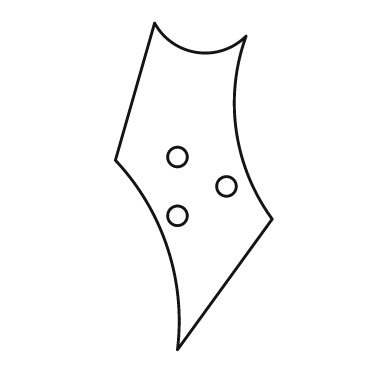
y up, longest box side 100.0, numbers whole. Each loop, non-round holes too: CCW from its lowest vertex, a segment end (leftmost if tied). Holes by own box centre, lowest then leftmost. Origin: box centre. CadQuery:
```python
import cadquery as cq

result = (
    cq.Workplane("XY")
    .moveTo(-5.0, -50.0)
    .lineTo(24.0, -10.0)
    .threePointArc((13.0, 17.0), (16.0, 46.0))
    .threePointArc((1.0, 41.0), (-12.0, 50.0))
    .lineTo(-24.0, 8.0)
    .threePointArc((-8.0, -19.0), (-5.0, -50.0))
    .close()
    .moveTo(-5.0, -9.0)
    .circle(3.0)
    .moveTo(10.0, 0.0)
    .circle(3.0)
    .moveTo(-5.0, 9.0)
    .circle(3.0)
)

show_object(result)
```